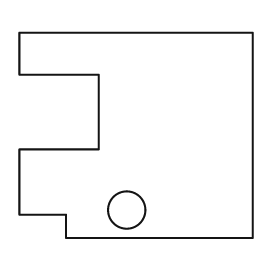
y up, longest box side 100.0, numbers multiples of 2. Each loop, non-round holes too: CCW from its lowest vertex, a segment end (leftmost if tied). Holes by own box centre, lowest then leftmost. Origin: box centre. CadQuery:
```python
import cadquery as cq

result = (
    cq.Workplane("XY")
    .moveTo(-30.0, -44.0)
    .lineTo(50.0, -44.0)
    .lineTo(50.0, 44.0)
    .lineTo(-50.0, 44.0)
    .lineTo(-50.0, 26.0)
    .lineTo(-16.0, 26.0)
    .lineTo(-16.0, -6.0)
    .lineTo(-50.0, -6.0)
    .lineTo(-50.0, -34.0)
    .lineTo(-30.0, -34.0)
    .close()
    .moveTo(-4.0, -32.0)
    .circle(8.0)
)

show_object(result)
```